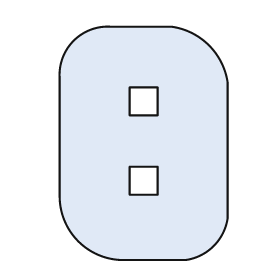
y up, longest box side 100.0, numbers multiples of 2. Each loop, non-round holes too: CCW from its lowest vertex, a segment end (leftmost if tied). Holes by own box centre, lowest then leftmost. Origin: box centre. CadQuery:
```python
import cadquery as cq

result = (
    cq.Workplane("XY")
    .moveTo(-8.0, -50.0)
    .lineTo(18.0, -50.0)
    .threePointArc((30.0, -44.0), (36.0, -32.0))
    .lineTo(36.0, 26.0)
    .threePointArc((28.0, 42.0), (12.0, 50.0))
    .lineTo(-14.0, 50.0)
    .threePointArc((-30.0, 44.0), (-36.0, 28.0))
    .lineTo(-36.0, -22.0)
    .threePointArc((-28.0, -42.0), (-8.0, -50.0))
    .close()
    .moveTo(-6.0, -22.0)
    .lineTo(6.0, -22.0)
    .lineTo(6.0, -10.0)
    .lineTo(-6.0, -10.0)
    .close()
    .moveTo(-6.0, 12.0)
    .lineTo(6.0, 12.0)
    .lineTo(6.0, 24.0)
    .lineTo(-6.0, 24.0)
    .close()
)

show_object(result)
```